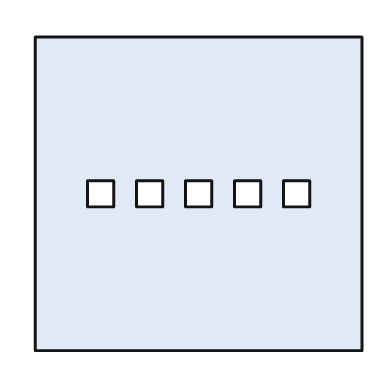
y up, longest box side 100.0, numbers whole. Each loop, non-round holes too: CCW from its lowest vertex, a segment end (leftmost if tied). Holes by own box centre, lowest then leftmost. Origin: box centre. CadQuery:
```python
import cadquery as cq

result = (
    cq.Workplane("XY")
    .moveTo(-50.0, -48.0)
    .lineTo(50.0, -48.0)
    .lineTo(50.0, 48.0)
    .lineTo(-50.0, 48.0)
    .close()
    .moveTo(-34.0, -4.0)
    .lineTo(-26.0, -4.0)
    .lineTo(-26.0, 4.0)
    .lineTo(-34.0, 4.0)
    .close()
    .moveTo(-19.0, -4.0)
    .lineTo(-11.0, -4.0)
    .lineTo(-11.0, 4.0)
    .lineTo(-19.0, 4.0)
    .close()
    .moveTo(-4.0, -4.0)
    .lineTo(4.0, -4.0)
    .lineTo(4.0, 4.0)
    .lineTo(-4.0, 4.0)
    .close()
    .moveTo(11.0, -4.0)
    .lineTo(19.0, -4.0)
    .lineTo(19.0, 4.0)
    .lineTo(11.0, 4.0)
    .close()
    .moveTo(26.0, -4.0)
    .lineTo(34.0, -4.0)
    .lineTo(34.0, 4.0)
    .lineTo(26.0, 4.0)
    .close()
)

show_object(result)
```